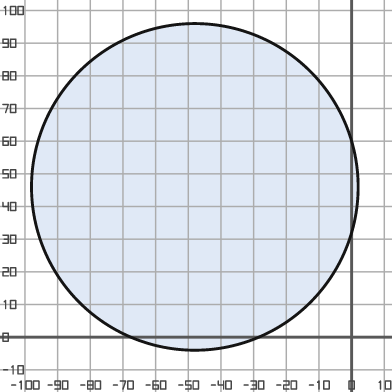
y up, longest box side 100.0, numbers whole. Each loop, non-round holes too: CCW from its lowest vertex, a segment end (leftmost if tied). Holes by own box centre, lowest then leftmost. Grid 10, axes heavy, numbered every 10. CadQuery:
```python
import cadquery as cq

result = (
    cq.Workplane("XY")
    .moveTo(-48.0, 46.0)
    .circle(50.0)
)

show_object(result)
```